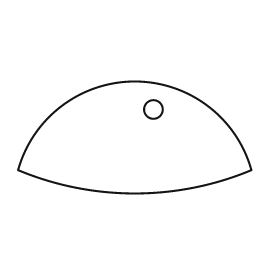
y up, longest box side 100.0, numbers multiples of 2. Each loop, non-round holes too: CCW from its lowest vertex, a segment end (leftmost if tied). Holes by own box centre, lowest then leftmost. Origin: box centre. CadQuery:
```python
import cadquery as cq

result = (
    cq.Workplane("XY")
    .moveTo(-50.0, -14.0)
    .threePointArc((0.0, -24.0), (50.0, -14.0))
    .threePointArc((0.0, 24.0), (-50.0, -14.0))
    .close()
    .moveTo(8.0, 12.0)
    .circle(4.0)
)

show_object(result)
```